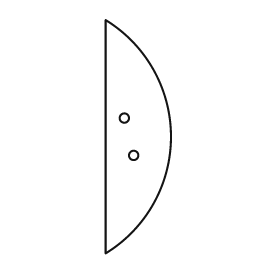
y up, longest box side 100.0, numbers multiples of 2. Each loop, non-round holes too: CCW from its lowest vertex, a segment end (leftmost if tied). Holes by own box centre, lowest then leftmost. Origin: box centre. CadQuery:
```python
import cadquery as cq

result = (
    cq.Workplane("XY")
    .moveTo(-14.0, -50.0)
    .threePointArc((14.0, 0.0), (-14.0, 50.0))
    .close()
    .moveTo(-2.0, -8.0)
    .circle(2.0)
    .moveTo(-6.0, 8.0)
    .circle(2.0)
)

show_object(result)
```